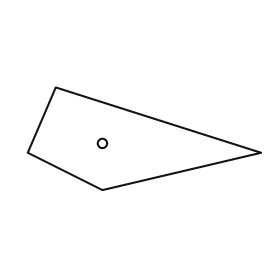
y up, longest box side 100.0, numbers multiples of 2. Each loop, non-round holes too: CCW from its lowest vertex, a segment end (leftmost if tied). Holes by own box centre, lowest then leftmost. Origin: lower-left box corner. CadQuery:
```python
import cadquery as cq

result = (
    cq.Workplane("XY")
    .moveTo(32.0, 0.0)
    .lineTo(100.0, 16.0)
    .lineTo(12.0, 44.0)
    .lineTo(0.0, 16.0)
    .close()
    .moveTo(32.0, 20.0)
    .circle(2.0)
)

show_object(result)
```